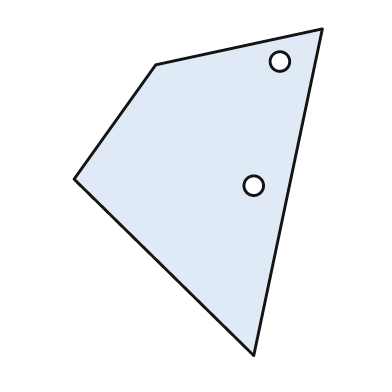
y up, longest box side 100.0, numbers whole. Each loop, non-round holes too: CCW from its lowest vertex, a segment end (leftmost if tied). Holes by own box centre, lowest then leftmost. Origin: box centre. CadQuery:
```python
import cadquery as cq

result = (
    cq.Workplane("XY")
    .moveTo(17.0, -50.0)
    .lineTo(38.0, 50.0)
    .lineTo(-13.0, 39.0)
    .lineTo(-38.0, 4.0)
    .close()
    .moveTo(17.0, 2.0)
    .circle(3.0)
    .moveTo(25.0, 40.0)
    .circle(3.0)
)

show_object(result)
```